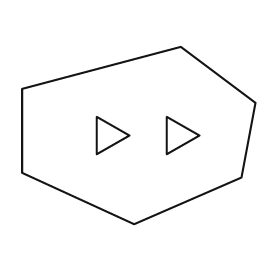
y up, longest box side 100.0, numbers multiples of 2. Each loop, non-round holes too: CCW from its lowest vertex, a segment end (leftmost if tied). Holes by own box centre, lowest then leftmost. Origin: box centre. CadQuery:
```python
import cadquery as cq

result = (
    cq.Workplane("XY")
    .moveTo(-2.0, -38.0)
    .lineTo(44.0, -18.0)
    .lineTo(50.0, 14.0)
    .lineTo(18.0, 38.0)
    .lineTo(-50.0, 20.0)
    .lineTo(-50.0, -16.0)
    .close()
    .moveTo(-18.0, -8.0)
    .lineTo(-4.0, 0.0)
    .lineTo(-18.0, 8.0)
    .close()
    .moveTo(12.0, -8.0)
    .lineTo(26.0, 0.0)
    .lineTo(12.0, 8.0)
    .close()
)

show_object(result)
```